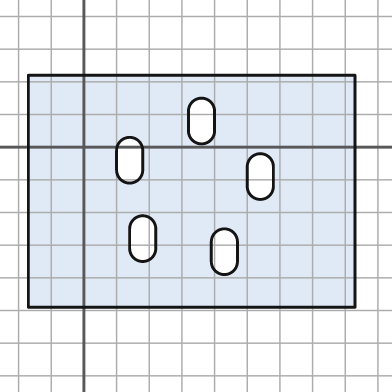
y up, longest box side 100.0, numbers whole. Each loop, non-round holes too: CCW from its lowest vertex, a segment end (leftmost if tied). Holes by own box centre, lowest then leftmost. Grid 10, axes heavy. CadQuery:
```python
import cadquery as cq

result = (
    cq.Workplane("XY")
    .moveTo(-17.0, -49.0)
    .lineTo(83.0, -49.0)
    .lineTo(83.0, 22.0)
    .lineTo(-17.0, 22.0)
    .close()
    .moveTo(39.0, -35.0)
    .threePointArc((43.0, -39.0), (47.0, -35.0))
    .lineTo(47.0, -29.0)
    .threePointArc((43.0, -25.0), (39.0, -29.0))
    .close()
    .moveTo(14.0, -31.0)
    .threePointArc((18.0, -35.0), (22.0, -31.0))
    .lineTo(22.0, -25.0)
    .threePointArc((18.0, -21.0), (14.0, -25.0))
    .close()
    .moveTo(50.0, -12.0)
    .threePointArc((54.0, -16.0), (58.0, -12.0))
    .lineTo(58.0, -6.0)
    .threePointArc((54.0, -2.0), (50.0, -6.0))
    .close()
    .moveTo(10.0, -7.0)
    .threePointArc((14.0, -11.0), (18.0, -7.0))
    .lineTo(18.0, -1.0)
    .threePointArc((14.0, 3.0), (10.0, -1.0))
    .close()
    .moveTo(32.0, 5.0)
    .threePointArc((36.0, 1.0), (40.0, 5.0))
    .lineTo(40.0, 11.0)
    .threePointArc((36.0, 15.0), (32.0, 11.0))
    .close()
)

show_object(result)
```